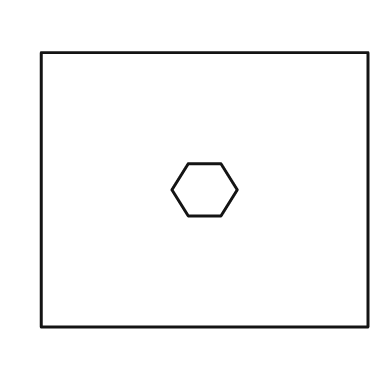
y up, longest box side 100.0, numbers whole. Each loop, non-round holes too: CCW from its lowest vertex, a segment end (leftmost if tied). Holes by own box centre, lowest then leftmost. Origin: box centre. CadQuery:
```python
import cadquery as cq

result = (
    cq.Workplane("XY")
    .moveTo(-50.0, -42.0)
    .lineTo(50.0, -42.0)
    .lineTo(50.0, 42.0)
    .lineTo(-50.0, 42.0)
    .close()
    .moveTo(-5.0, -8.0)
    .lineTo(5.0, -8.0)
    .lineTo(10.0, 0.0)
    .lineTo(5.0, 8.0)
    .lineTo(-5.0, 8.0)
    .lineTo(-10.0, 0.0)
    .close()
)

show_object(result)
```